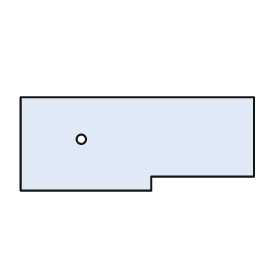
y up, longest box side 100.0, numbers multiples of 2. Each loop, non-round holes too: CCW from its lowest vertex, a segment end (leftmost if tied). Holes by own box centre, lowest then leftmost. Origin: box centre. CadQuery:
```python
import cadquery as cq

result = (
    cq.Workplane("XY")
    .moveTo(-50.0, -20.0)
    .lineTo(6.0, -20.0)
    .lineTo(6.0, -14.0)
    .lineTo(50.0, -14.0)
    .lineTo(50.0, 20.0)
    .lineTo(-50.0, 20.0)
    .close()
    .moveTo(-24.0, 2.0)
    .circle(2.0)
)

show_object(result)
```